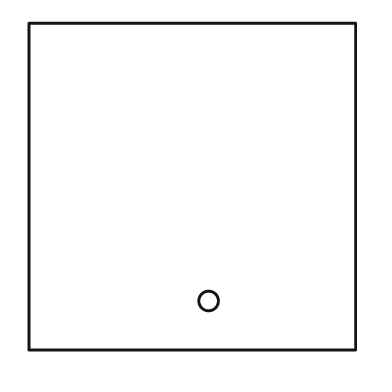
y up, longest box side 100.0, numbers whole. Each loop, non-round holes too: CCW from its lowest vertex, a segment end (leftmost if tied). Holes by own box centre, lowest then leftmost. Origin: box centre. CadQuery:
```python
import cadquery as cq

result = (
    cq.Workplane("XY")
    .moveTo(-50.0, -50.0)
    .lineTo(50.0, -50.0)
    .lineTo(50.0, 50.0)
    .lineTo(-50.0, 50.0)
    .close()
    .moveTo(5.0, -35.0)
    .circle(3.0)
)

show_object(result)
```